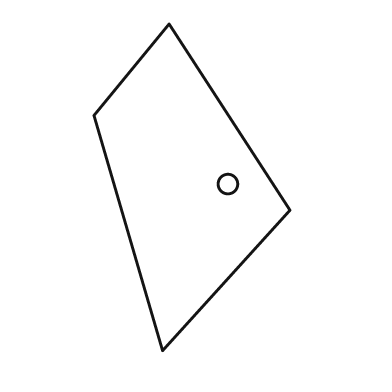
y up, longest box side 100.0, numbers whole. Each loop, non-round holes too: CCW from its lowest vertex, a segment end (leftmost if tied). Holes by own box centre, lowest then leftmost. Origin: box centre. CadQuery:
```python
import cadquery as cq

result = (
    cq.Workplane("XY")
    .moveTo(-9.0, -50.0)
    .lineTo(30.0, -7.0)
    .lineTo(-7.0, 50.0)
    .lineTo(-30.0, 22.0)
    .close()
    .moveTo(11.0, 1.0)
    .circle(3.0)
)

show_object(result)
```